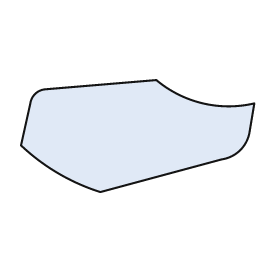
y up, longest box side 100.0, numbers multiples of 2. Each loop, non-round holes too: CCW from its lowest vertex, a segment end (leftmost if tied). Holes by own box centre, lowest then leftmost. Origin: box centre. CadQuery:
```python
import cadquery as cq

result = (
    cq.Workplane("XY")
    .moveTo(-16.0, -24.0)
    .lineTo(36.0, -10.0)
    .threePointArc((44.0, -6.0), (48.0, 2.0))
    .lineTo(50.0, 14.0)
    .threePointArc((28.0, 14.0), (8.0, 24.0))
    .lineTo(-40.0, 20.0)
    .threePointArc((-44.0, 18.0), (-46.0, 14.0))
    .lineTo(-50.0, -4.0)
    .threePointArc((-34.0, -16.0), (-16.0, -24.0))
    .close()
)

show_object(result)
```